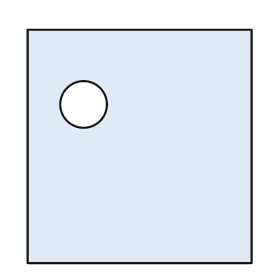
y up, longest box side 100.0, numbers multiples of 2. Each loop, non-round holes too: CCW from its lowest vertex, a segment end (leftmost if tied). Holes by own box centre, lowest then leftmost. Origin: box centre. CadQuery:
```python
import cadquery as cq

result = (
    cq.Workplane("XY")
    .moveTo(-48.0, -50.0)
    .lineTo(48.0, -50.0)
    .lineTo(48.0, 50.0)
    .lineTo(-48.0, 50.0)
    .close()
    .moveTo(-24.0, 18.0)
    .circle(10.0)
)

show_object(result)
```